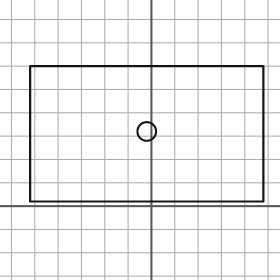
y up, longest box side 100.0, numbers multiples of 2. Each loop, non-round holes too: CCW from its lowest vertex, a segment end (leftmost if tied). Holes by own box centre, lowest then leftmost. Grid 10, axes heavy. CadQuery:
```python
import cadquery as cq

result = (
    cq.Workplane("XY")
    .moveTo(-52.0, 2.0)
    .lineTo(48.0, 2.0)
    .lineTo(48.0, 60.0)
    .lineTo(-52.0, 60.0)
    .close()
    .moveTo(-2.0, 32.0)
    .circle(4.0)
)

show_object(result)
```